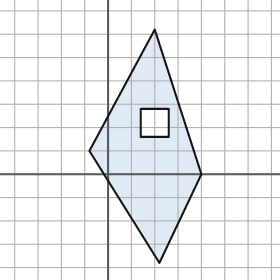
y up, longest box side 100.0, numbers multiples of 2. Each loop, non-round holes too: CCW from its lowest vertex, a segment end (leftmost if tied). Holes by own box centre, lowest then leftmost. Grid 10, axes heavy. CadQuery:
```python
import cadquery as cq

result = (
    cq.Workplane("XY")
    .moveTo(22.0, -38.0)
    .lineTo(40.0, 0.0)
    .lineTo(20.0, 62.0)
    .lineTo(-8.0, 10.0)
    .close()
    .moveTo(14.0, 16.0)
    .lineTo(26.0, 16.0)
    .lineTo(26.0, 28.0)
    .lineTo(14.0, 28.0)
    .close()
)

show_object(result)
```